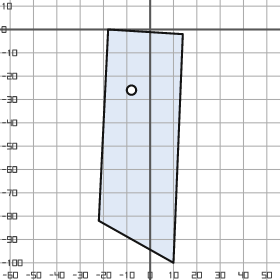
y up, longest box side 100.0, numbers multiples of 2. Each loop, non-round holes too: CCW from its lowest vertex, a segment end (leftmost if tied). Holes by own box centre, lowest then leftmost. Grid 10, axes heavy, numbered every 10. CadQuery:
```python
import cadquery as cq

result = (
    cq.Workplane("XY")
    .moveTo(10.0, -100.0)
    .lineTo(14.0, -2.0)
    .lineTo(-18.0, 0.0)
    .lineTo(-22.0, -82.0)
    .close()
    .moveTo(-8.0, -26.0)
    .circle(2.0)
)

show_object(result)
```